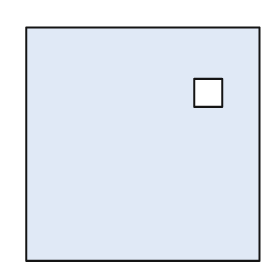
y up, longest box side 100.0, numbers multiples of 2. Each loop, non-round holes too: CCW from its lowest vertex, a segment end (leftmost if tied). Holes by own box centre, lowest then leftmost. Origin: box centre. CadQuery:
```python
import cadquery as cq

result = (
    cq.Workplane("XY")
    .moveTo(-50.0, -50.0)
    .lineTo(50.0, -50.0)
    .lineTo(50.0, 50.0)
    .lineTo(-50.0, 50.0)
    .close()
    .moveTo(22.0, 16.0)
    .lineTo(34.0, 16.0)
    .lineTo(34.0, 28.0)
    .lineTo(22.0, 28.0)
    .close()
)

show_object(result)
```